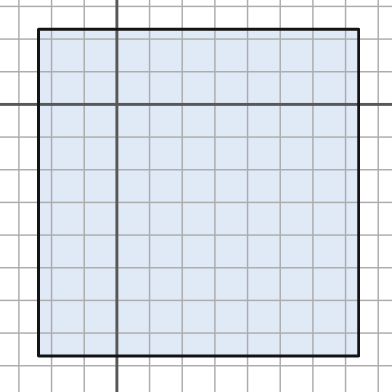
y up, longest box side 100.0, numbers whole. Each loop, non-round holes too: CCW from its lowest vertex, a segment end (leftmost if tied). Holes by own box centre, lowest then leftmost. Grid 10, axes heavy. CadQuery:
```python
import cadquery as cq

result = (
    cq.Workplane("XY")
    .moveTo(-24.0, -77.0)
    .lineTo(74.0, -77.0)
    .lineTo(74.0, 23.0)
    .lineTo(-24.0, 23.0)
    .close()
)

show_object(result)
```